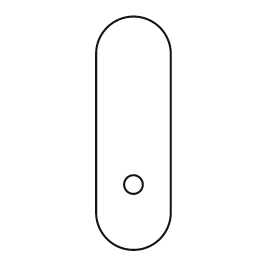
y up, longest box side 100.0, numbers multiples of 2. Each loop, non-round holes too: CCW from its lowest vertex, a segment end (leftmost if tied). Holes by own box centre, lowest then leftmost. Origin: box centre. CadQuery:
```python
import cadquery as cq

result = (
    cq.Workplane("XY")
    .moveTo(-16.0, -34.0)
    .threePointArc((0.0, -50.0), (16.0, -34.0))
    .lineTo(16.0, 34.0)
    .threePointArc((0.0, 50.0), (-16.0, 34.0))
    .close()
    .moveTo(0.0, -22.0)
    .circle(4.0)
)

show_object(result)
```